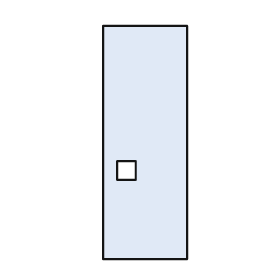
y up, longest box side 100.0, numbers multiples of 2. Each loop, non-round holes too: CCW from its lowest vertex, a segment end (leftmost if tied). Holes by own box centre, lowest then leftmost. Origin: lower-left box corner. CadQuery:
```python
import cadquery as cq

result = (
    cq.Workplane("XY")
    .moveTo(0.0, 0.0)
    .lineTo(36.0, 0.0)
    .lineTo(36.0, 100.0)
    .lineTo(0.0, 100.0)
    .close()
    .moveTo(6.0, 34.0)
    .lineTo(14.0, 34.0)
    .lineTo(14.0, 42.0)
    .lineTo(6.0, 42.0)
    .close()
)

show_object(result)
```